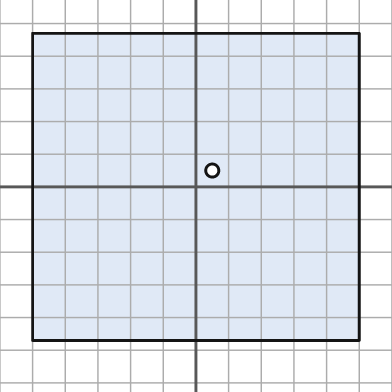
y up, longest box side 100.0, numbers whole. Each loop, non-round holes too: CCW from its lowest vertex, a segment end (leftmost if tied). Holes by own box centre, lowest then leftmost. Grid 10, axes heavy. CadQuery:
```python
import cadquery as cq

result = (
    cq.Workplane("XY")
    .moveTo(-50.0, -47.0)
    .lineTo(50.0, -47.0)
    .lineTo(50.0, 47.0)
    .lineTo(-50.0, 47.0)
    .close()
    .moveTo(5.0, 5.0)
    .circle(2.0)
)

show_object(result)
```